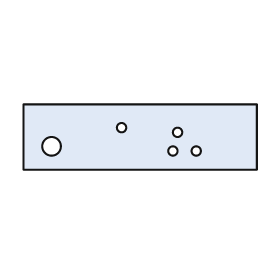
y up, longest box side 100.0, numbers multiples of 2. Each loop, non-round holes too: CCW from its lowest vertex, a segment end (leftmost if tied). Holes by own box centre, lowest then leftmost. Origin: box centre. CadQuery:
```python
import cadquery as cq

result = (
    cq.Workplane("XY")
    .moveTo(-50.0, -14.0)
    .lineTo(50.0, -14.0)
    .lineTo(50.0, 14.0)
    .lineTo(-50.0, 14.0)
    .close()
    .moveTo(14.0, -6.0)
    .circle(2.0)
    .moveTo(24.0, -6.0)
    .circle(2.0)
    .moveTo(-38.0, -4.0)
    .circle(4.0)
    .moveTo(16.0, 2.0)
    .circle(2.0)
    .moveTo(-8.0, 4.0)
    .circle(2.0)
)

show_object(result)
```